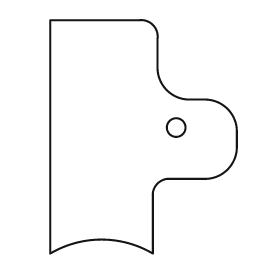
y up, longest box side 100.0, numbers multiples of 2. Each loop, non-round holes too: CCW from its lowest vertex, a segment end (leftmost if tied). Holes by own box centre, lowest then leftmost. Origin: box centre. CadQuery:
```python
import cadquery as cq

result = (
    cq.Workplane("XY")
    .moveTo(-40.0, -50.0)
    .threePointArc((-18.0, -44.0), (4.0, -50.0))
    .lineTo(4.0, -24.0)
    .threePointArc((6.0, -20.0), (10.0, -18.0))
    .lineTo(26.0, -18.0)
    .threePointArc((36.0, -14.0), (40.0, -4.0))
    .lineTo(40.0, 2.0)
    .threePointArc((36.0, 12.0), (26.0, 16.0))
    .lineTo(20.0, 16.0)
    .threePointArc((10.0, 20.0), (6.0, 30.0))
    .lineTo(6.0, 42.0)
    .threePointArc((4.0, 48.0), (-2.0, 50.0))
    .lineTo(-40.0, 50.0)
    .close()
    .moveTo(14.0, 4.0)
    .circle(4.0)
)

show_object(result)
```